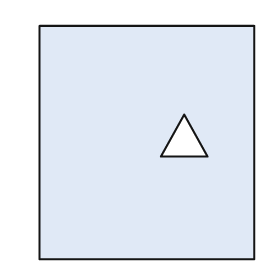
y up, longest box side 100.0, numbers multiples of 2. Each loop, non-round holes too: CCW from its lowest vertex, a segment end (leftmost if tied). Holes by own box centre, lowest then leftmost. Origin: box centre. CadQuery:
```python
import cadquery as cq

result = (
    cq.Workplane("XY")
    .moveTo(-46.0, -50.0)
    .lineTo(46.0, -50.0)
    .lineTo(46.0, 50.0)
    .lineTo(-46.0, 50.0)
    .close()
    .moveTo(6.0, -6.0)
    .lineTo(26.0, -6.0)
    .lineTo(16.0, 12.0)
    .close()
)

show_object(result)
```